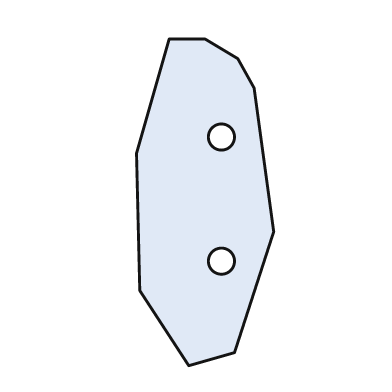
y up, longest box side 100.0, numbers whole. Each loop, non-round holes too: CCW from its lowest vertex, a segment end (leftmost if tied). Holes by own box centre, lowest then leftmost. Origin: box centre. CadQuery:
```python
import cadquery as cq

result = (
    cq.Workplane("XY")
    .moveTo(-5.0, -50.0)
    .lineTo(9.0, -46.0)
    .lineTo(21.0, -9.0)
    .lineTo(15.0, 35.0)
    .lineTo(10.0, 44.0)
    .lineTo(0.0, 50.0)
    .lineTo(-11.0, 50.0)
    .lineTo(-21.0, 15.0)
    .lineTo(-20.0, -27.0)
    .close()
    .moveTo(5.0, -18.0)
    .circle(4.0)
    .moveTo(5.0, 20.0)
    .circle(4.0)
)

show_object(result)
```